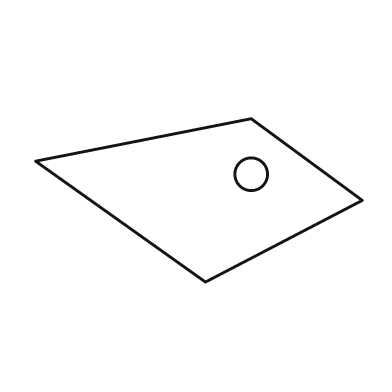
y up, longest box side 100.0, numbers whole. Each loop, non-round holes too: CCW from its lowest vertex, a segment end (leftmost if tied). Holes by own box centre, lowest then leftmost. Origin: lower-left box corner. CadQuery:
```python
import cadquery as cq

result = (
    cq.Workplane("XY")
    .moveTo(52.0, 0.0)
    .lineTo(100.0, 25.0)
    .lineTo(66.0, 50.0)
    .lineTo(0.0, 37.0)
    .close()
    .moveTo(66.0, 33.0)
    .circle(5.0)
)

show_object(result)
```